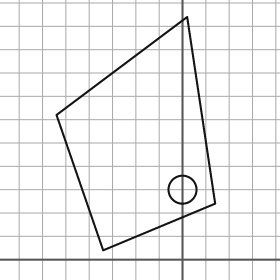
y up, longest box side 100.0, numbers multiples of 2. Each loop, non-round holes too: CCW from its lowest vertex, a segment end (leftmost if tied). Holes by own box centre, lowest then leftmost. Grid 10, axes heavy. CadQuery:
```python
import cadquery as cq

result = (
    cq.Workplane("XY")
    .moveTo(-34.0, 4.0)
    .lineTo(14.0, 24.0)
    .lineTo(2.0, 104.0)
    .lineTo(-54.0, 62.0)
    .close()
    .moveTo(0.0, 30.0)
    .circle(6.0)
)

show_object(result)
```